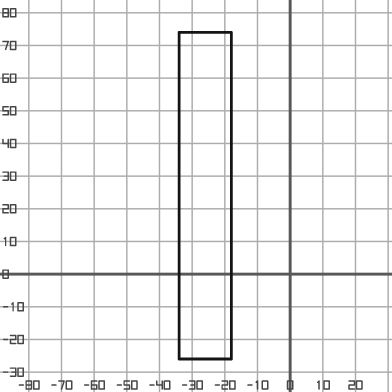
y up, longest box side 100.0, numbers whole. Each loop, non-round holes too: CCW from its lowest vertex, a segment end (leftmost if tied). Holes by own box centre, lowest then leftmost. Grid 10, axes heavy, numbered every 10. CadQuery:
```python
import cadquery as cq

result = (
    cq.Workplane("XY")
    .moveTo(-34.0, -26.0)
    .lineTo(-18.0, -26.0)
    .lineTo(-18.0, 74.0)
    .lineTo(-34.0, 74.0)
    .close()
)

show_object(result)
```